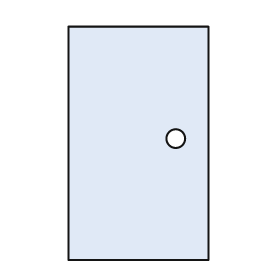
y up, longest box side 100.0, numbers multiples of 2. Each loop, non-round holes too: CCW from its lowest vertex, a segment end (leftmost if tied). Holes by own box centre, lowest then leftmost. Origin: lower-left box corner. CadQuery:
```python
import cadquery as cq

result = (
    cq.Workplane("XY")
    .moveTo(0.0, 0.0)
    .lineTo(60.0, 0.0)
    .lineTo(60.0, 100.0)
    .lineTo(0.0, 100.0)
    .close()
    .moveTo(46.0, 52.0)
    .circle(4.0)
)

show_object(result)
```